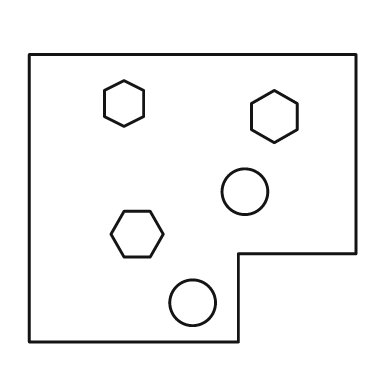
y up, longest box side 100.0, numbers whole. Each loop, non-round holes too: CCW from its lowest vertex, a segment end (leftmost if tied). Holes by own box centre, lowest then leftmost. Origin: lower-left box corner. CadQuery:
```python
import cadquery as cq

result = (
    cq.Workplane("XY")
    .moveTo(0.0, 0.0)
    .lineTo(64.0, 0.0)
    .lineTo(64.0, 27.0)
    .lineTo(100.0, 27.0)
    .lineTo(100.0, 88.0)
    .lineTo(0.0, 88.0)
    .close()
    .moveTo(50.0, 12.0)
    .circle(7.0)
    .moveTo(29.0, 26.0)
    .lineTo(37.0, 26.0)
    .lineTo(41.0, 33.0)
    .lineTo(37.0, 40.0)
    .lineTo(29.0, 40.0)
    .lineTo(25.0, 33.0)
    .close()
    .moveTo(66.0, 46.0)
    .circle(7.0)
    .moveTo(75.0, 61.0)
    .lineTo(82.0, 65.0)
    .lineTo(82.0, 73.0)
    .lineTo(75.0, 77.0)
    .lineTo(68.0, 73.0)
    .lineTo(68.0, 65.0)
    .close()
    .moveTo(29.0, 66.0)
    .lineTo(35.0, 69.0)
    .lineTo(35.0, 77.0)
    .lineTo(29.0, 80.0)
    .lineTo(23.0, 77.0)
    .lineTo(23.0, 69.0)
    .close()
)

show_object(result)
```